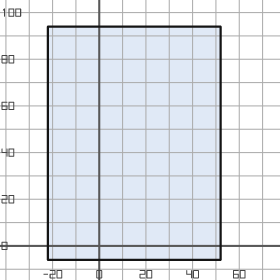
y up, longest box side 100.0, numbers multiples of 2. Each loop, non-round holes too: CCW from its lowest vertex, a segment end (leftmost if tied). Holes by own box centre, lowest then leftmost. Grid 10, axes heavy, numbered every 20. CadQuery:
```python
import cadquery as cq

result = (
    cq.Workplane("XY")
    .moveTo(-22.0, -6.0)
    .lineTo(52.0, -6.0)
    .lineTo(52.0, 94.0)
    .lineTo(-22.0, 94.0)
    .close()
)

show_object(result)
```